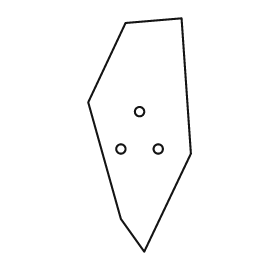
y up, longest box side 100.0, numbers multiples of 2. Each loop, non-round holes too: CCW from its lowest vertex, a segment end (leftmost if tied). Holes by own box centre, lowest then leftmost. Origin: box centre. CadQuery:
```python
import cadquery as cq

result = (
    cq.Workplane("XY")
    .moveTo(2.0, -50.0)
    .lineTo(22.0, -8.0)
    .lineTo(18.0, 50.0)
    .lineTo(-6.0, 48.0)
    .lineTo(-22.0, 14.0)
    .lineTo(-8.0, -36.0)
    .close()
    .moveTo(-8.0, -6.0)
    .circle(2.0)
    .moveTo(8.0, -6.0)
    .circle(2.0)
    .moveTo(0.0, 10.0)
    .circle(2.0)
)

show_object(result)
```